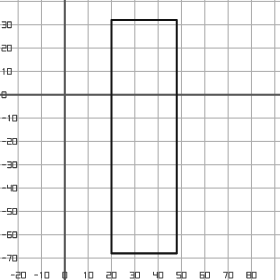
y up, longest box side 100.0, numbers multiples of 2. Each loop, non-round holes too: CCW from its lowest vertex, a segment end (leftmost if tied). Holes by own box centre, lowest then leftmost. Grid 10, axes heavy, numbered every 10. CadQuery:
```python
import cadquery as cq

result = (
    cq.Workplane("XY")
    .moveTo(20.0, -68.0)
    .lineTo(48.0, -68.0)
    .lineTo(48.0, 32.0)
    .lineTo(20.0, 32.0)
    .close()
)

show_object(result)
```